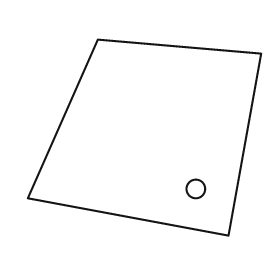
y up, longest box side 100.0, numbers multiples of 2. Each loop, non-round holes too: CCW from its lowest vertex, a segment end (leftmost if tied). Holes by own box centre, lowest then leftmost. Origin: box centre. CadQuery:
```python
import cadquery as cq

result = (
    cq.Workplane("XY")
    .moveTo(36.0, -42.0)
    .lineTo(50.0, 36.0)
    .lineTo(-20.0, 42.0)
    .lineTo(-50.0, -26.0)
    .close()
    .moveTo(22.0, -22.0)
    .circle(4.0)
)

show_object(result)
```